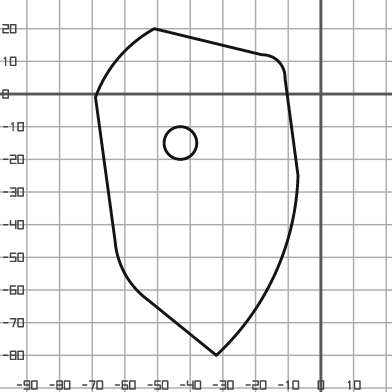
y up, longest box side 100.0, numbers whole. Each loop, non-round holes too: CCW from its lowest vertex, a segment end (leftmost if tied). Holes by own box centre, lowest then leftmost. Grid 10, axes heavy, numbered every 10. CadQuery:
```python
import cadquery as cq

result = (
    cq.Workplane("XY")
    .moveTo(-32.0, -80.0)
    .threePointArc((-14.0, -55.0), (-7.0, -25.0))
    .lineTo(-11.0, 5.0)
    .threePointArc((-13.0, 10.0), (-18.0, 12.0))
    .lineTo(-51.0, 20.0)
    .threePointArc((-62.0, 11.0), (-69.0, -1.0))
    .lineTo(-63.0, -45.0)
    .threePointArc((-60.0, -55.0), (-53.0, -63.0))
    .close()
    .moveTo(-43.0, -15.0)
    .circle(5.0)
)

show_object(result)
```